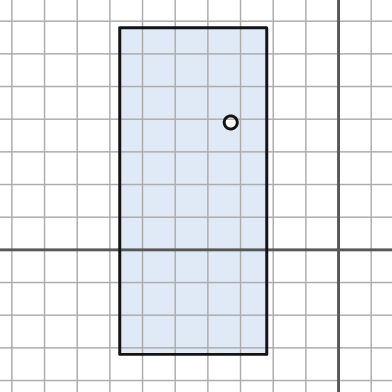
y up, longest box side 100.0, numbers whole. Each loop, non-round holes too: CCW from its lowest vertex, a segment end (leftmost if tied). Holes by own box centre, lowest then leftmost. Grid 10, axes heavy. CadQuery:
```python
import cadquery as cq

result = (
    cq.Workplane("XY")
    .moveTo(-67.0, -32.0)
    .lineTo(-22.0, -32.0)
    .lineTo(-22.0, 68.0)
    .lineTo(-67.0, 68.0)
    .close()
    .moveTo(-33.0, 39.0)
    .circle(2.0)
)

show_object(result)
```